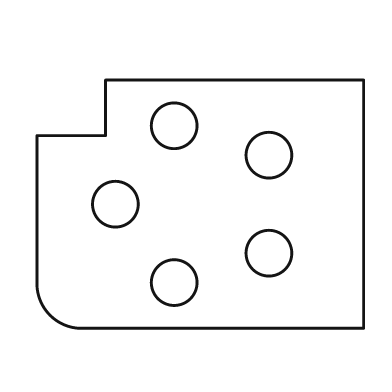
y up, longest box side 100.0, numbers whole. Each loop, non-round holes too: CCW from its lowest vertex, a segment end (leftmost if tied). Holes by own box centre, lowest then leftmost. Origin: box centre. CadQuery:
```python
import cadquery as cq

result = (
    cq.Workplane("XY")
    .moveTo(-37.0, -38.0)
    .lineTo(50.0, -38.0)
    .lineTo(50.0, 38.0)
    .lineTo(-29.0, 38.0)
    .lineTo(-29.0, 21.0)
    .lineTo(-50.0, 21.0)
    .lineTo(-50.0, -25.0)
    .threePointArc((-46.0, -34.0), (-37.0, -38.0))
    .close()
    .moveTo(-8.0, -24.0)
    .circle(7.0)
    .moveTo(21.0, -15.0)
    .circle(7.0)
    .moveTo(-26.0, 0.0)
    .circle(7.0)
    .moveTo(21.0, 15.0)
    .circle(7.0)
    .moveTo(-8.0, 24.0)
    .circle(7.0)
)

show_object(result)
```